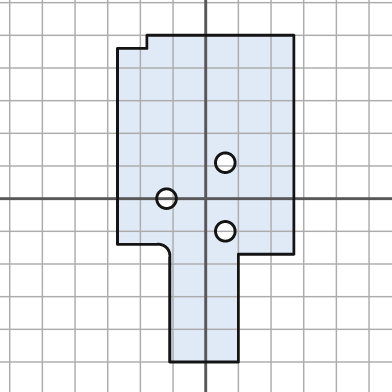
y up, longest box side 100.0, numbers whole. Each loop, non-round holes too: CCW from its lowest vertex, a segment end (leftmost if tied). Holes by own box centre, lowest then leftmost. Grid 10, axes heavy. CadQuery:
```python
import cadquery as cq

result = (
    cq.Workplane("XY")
    .moveTo(-11.0, -50.0)
    .lineTo(10.0, -50.0)
    .lineTo(10.0, -17.0)
    .lineTo(27.0, -17.0)
    .lineTo(27.0, 50.0)
    .lineTo(-18.0, 50.0)
    .lineTo(-18.0, 46.0)
    .lineTo(-27.0, 46.0)
    .lineTo(-27.0, -14.0)
    .lineTo(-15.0, -14.0)
    .threePointArc((-12.0, -15.0), (-11.0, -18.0))
    .close()
    .moveTo(6.0, -10.0)
    .circle(3.0)
    .moveTo(-12.0, 0.0)
    .circle(3.0)
    .moveTo(6.0, 11.0)
    .circle(3.0)
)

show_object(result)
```